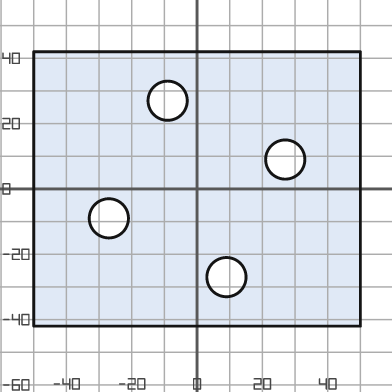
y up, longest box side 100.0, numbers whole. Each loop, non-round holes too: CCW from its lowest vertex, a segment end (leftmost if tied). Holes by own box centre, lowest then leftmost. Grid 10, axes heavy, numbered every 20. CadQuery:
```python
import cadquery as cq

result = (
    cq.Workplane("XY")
    .moveTo(-50.0, -42.0)
    .lineTo(50.0, -42.0)
    .lineTo(50.0, 42.0)
    .lineTo(-50.0, 42.0)
    .close()
    .moveTo(9.0, -27.0)
    .circle(6.0)
    .moveTo(-27.0, -9.0)
    .circle(6.0)
    .moveTo(27.0, 9.0)
    .circle(6.0)
    .moveTo(-9.0, 27.0)
    .circle(6.0)
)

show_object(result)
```